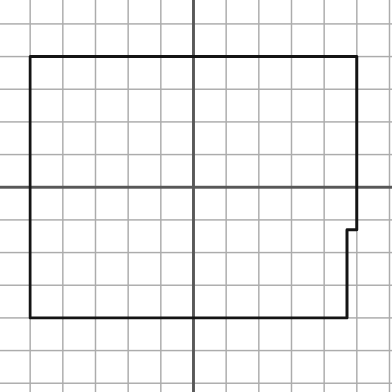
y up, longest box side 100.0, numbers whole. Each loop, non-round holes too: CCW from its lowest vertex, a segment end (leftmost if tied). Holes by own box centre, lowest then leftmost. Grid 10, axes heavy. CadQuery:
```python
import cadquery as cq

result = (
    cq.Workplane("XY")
    .moveTo(-50.0, -40.0)
    .lineTo(47.0, -40.0)
    .lineTo(47.0, -13.0)
    .lineTo(50.0, -13.0)
    .lineTo(50.0, 40.0)
    .lineTo(-50.0, 40.0)
    .close()
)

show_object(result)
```